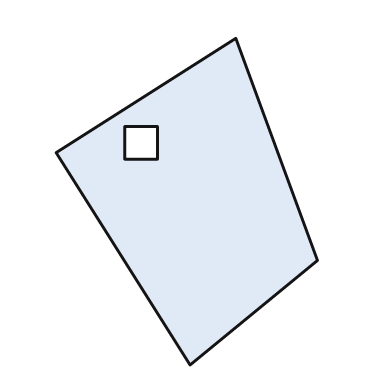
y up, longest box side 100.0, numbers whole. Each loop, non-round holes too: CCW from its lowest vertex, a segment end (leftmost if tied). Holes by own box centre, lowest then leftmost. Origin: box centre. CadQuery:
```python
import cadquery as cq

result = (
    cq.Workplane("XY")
    .moveTo(1.0, -50.0)
    .lineTo(40.0, -18.0)
    .lineTo(15.0, 50.0)
    .lineTo(-40.0, 15.0)
    .close()
    .moveTo(-19.0, 13.0)
    .lineTo(-9.0, 13.0)
    .lineTo(-9.0, 23.0)
    .lineTo(-19.0, 23.0)
    .close()
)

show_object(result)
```